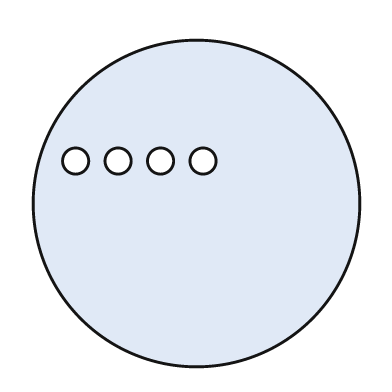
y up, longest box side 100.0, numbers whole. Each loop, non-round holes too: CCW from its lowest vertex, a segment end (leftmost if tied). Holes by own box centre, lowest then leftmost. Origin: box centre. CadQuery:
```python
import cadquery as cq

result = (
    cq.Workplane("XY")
    .moveTo(0.0, 0.0)
    .circle(50.0)
    .moveTo(-37.0, 13.0)
    .circle(4.0)
    .moveTo(-24.0, 13.0)
    .circle(4.0)
    .moveTo(-11.0, 13.0)
    .circle(4.0)
    .moveTo(2.0, 13.0)
    .circle(4.0)
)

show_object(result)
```